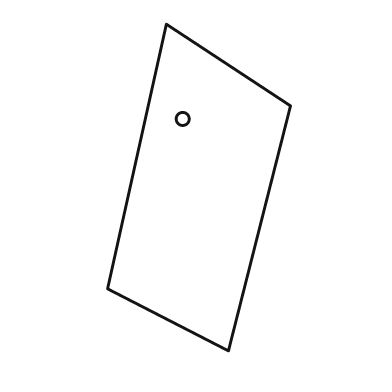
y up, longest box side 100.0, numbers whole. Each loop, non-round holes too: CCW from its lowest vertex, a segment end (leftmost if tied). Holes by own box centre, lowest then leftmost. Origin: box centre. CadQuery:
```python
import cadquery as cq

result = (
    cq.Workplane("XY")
    .moveTo(9.0, -50.0)
    .lineTo(28.0, 25.0)
    .lineTo(-10.0, 50.0)
    .lineTo(-28.0, -31.0)
    .close()
    .moveTo(-5.0, 21.0)
    .circle(2.0)
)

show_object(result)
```